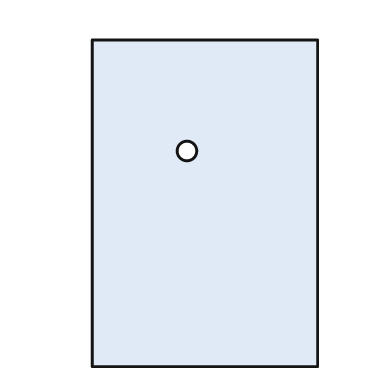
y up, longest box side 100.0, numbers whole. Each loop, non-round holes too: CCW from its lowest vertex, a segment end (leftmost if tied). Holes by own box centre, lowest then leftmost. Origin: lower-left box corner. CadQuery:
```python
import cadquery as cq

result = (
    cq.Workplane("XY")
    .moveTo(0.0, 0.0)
    .lineTo(69.0, 0.0)
    .lineTo(69.0, 100.0)
    .lineTo(0.0, 100.0)
    .close()
    .moveTo(29.0, 66.0)
    .circle(3.0)
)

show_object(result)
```